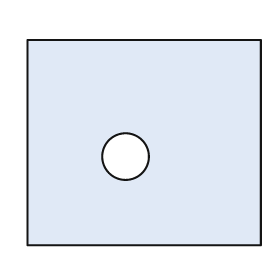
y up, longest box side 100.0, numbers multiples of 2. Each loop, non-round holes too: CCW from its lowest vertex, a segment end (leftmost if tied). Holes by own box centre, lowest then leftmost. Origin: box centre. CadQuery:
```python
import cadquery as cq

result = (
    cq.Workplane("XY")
    .moveTo(-50.0, -44.0)
    .lineTo(50.0, -44.0)
    .lineTo(50.0, 44.0)
    .lineTo(-50.0, 44.0)
    .close()
    .moveTo(-8.0, -6.0)
    .circle(10.0)
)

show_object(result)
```